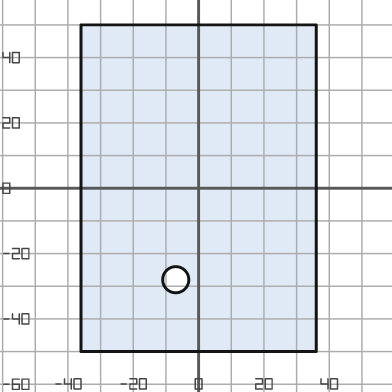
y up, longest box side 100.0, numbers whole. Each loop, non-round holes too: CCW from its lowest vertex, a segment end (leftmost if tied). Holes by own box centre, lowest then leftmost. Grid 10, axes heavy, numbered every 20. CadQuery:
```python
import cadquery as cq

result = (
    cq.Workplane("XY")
    .moveTo(-36.0, -50.0)
    .lineTo(36.0, -50.0)
    .lineTo(36.0, 50.0)
    .lineTo(-36.0, 50.0)
    .close()
    .moveTo(-7.0, -28.0)
    .circle(4.0)
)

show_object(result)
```